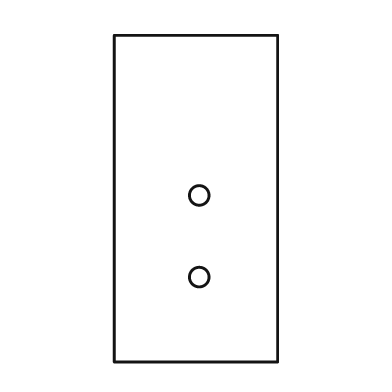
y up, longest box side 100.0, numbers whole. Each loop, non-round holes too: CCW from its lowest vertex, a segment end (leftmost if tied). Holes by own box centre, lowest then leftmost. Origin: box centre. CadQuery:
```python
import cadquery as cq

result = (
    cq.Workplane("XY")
    .moveTo(-25.0, -50.0)
    .lineTo(25.0, -50.0)
    .lineTo(25.0, 50.0)
    .lineTo(-25.0, 50.0)
    .close()
    .moveTo(1.0, -24.0)
    .circle(3.0)
    .moveTo(1.0, 1.0)
    .circle(3.0)
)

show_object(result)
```